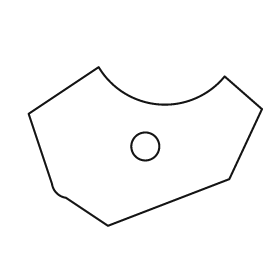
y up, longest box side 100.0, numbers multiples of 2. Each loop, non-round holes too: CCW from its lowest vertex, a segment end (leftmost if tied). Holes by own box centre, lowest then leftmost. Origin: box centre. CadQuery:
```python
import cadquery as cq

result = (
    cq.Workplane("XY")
    .moveTo(-16.0, -34.0)
    .lineTo(36.0, -14.0)
    .lineTo(50.0, 16.0)
    .lineTo(34.0, 30.0)
    .threePointArc((6.0, 18.0), (-20.0, 34.0))
    .lineTo(-50.0, 14.0)
    .lineTo(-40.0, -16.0)
    .threePointArc((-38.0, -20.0), (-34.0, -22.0))
    .close()
    .moveTo(0.0, 0.0)
    .circle(6.0)
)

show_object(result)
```